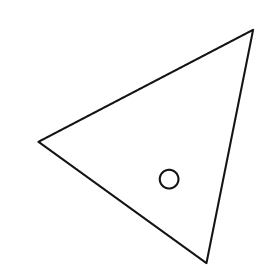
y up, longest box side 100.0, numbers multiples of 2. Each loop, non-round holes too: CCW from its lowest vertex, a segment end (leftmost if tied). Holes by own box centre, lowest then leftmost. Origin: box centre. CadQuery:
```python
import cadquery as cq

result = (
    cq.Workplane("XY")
    .moveTo(26.0, -50.0)
    .lineTo(46.0, 50.0)
    .lineTo(-46.0, 2.0)
    .close()
    .moveTo(10.0, -14.0)
    .circle(4.0)
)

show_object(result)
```